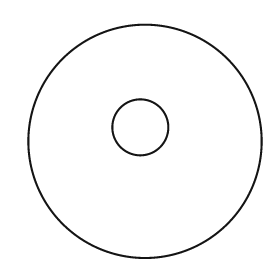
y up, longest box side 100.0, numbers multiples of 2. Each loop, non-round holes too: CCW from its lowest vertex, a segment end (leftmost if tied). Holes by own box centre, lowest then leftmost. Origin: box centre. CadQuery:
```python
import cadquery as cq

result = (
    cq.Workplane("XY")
    .moveTo(0.0, 0.0)
    .circle(50.0)
    .moveTo(-2.0, 6.0)
    .circle(12.0)
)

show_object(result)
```